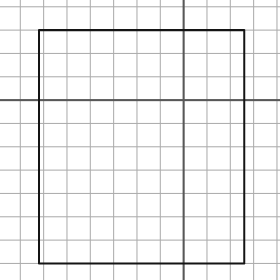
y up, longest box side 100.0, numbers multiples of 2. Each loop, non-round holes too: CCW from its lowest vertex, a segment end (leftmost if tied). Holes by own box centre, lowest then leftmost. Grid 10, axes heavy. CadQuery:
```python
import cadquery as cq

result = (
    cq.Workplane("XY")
    .moveTo(-62.0, -70.0)
    .lineTo(26.0, -70.0)
    .lineTo(26.0, 30.0)
    .lineTo(-62.0, 30.0)
    .close()
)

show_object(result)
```